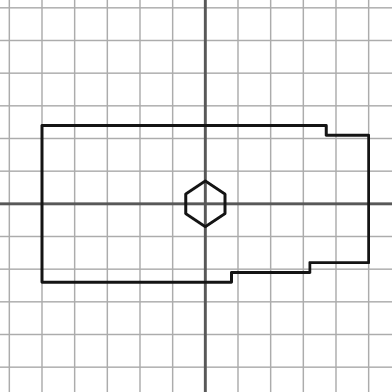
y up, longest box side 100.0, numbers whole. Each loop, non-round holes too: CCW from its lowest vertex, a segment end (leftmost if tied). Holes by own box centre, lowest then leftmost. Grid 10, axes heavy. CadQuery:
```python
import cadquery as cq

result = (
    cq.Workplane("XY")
    .moveTo(-50.0, -24.0)
    .lineTo(8.0, -24.0)
    .lineTo(8.0, -21.0)
    .lineTo(32.0, -21.0)
    .lineTo(32.0, -18.0)
    .lineTo(50.0, -18.0)
    .lineTo(50.0, 21.0)
    .lineTo(37.0, 21.0)
    .lineTo(37.0, 24.0)
    .lineTo(-50.0, 24.0)
    .close()
    .moveTo(0.0, -7.0)
    .lineTo(6.0, -3.0)
    .lineTo(6.0, 3.0)
    .lineTo(0.0, 7.0)
    .lineTo(-6.0, 3.0)
    .lineTo(-6.0, -3.0)
    .close()
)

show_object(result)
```